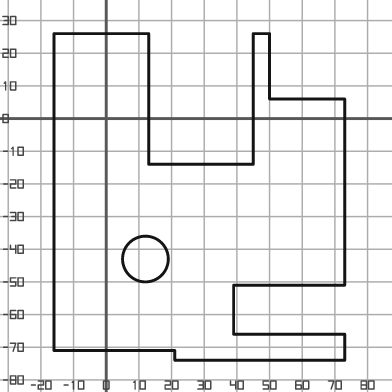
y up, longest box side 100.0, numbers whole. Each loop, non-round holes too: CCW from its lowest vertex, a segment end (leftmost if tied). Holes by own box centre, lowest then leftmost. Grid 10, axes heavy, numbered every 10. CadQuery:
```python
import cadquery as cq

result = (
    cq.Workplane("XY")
    .moveTo(21.0, -74.0)
    .lineTo(73.0, -74.0)
    .lineTo(73.0, -66.0)
    .lineTo(39.0, -66.0)
    .lineTo(39.0, -51.0)
    .lineTo(73.0, -51.0)
    .lineTo(73.0, 6.0)
    .lineTo(50.0, 6.0)
    .lineTo(50.0, 26.0)
    .lineTo(45.0, 26.0)
    .lineTo(45.0, -14.0)
    .lineTo(13.0, -14.0)
    .lineTo(13.0, 26.0)
    .lineTo(-16.0, 26.0)
    .lineTo(-16.0, -71.0)
    .lineTo(21.0, -71.0)
    .close()
    .moveTo(12.0, -43.0)
    .circle(7.0)
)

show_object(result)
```